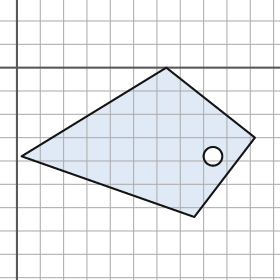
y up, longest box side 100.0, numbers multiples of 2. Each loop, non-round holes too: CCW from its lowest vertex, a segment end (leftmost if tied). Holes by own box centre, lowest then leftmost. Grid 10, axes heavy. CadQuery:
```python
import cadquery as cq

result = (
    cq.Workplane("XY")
    .moveTo(76.0, -64.0)
    .lineTo(102.0, -30.0)
    .lineTo(64.0, 0.0)
    .lineTo(2.0, -38.0)
    .close()
    .moveTo(84.0, -38.0)
    .circle(4.0)
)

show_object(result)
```